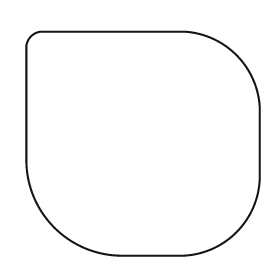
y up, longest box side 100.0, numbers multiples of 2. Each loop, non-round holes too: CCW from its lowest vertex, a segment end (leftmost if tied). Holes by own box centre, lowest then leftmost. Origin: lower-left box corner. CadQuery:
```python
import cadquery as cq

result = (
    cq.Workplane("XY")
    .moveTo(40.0, 0.0)
    .lineTo(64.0, 0.0)
    .threePointArc((90.0, 10.0), (100.0, 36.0))
    .lineTo(100.0, 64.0)
    .threePointArc((90.0, 86.0), (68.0, 96.0))
    .lineTo(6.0, 96.0)
    .threePointArc((2.0, 94.0), (0.0, 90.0))
    .lineTo(0.0, 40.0)
    .threePointArc((12.0, 12.0), (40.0, 0.0))
    .close()
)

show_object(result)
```